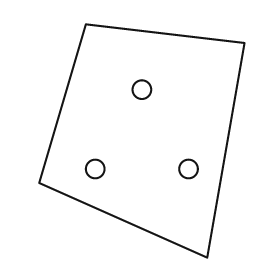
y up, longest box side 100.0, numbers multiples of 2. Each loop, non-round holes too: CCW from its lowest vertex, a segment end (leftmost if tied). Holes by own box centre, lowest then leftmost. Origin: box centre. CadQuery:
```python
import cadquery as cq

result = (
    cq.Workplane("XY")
    .moveTo(28.0, -50.0)
    .lineTo(44.0, 42.0)
    .lineTo(-24.0, 50.0)
    .lineTo(-44.0, -18.0)
    .close()
    .moveTo(-20.0, -12.0)
    .circle(4.0)
    .moveTo(20.0, -12.0)
    .circle(4.0)
    .moveTo(0.0, 22.0)
    .circle(4.0)
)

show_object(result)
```